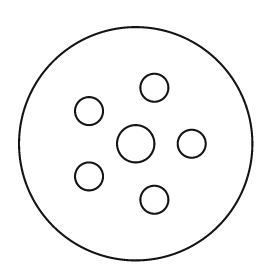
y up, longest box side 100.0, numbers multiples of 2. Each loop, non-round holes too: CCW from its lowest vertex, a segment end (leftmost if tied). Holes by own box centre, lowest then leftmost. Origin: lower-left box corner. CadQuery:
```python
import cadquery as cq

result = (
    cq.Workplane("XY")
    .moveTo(50.0, 50.0)
    .circle(50.0)
    .moveTo(58.0, 26.0)
    .circle(6.0)
    .moveTo(30.0, 36.0)
    .circle(6.0)
    .moveTo(50.0, 50.0)
    .circle(8.0)
    .moveTo(74.0, 50.0)
    .circle(6.0)
    .moveTo(30.0, 64.0)
    .circle(6.0)
    .moveTo(58.0, 74.0)
    .circle(6.0)
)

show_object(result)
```